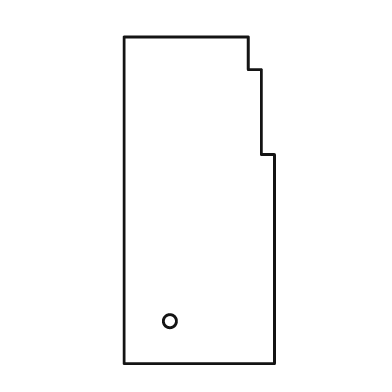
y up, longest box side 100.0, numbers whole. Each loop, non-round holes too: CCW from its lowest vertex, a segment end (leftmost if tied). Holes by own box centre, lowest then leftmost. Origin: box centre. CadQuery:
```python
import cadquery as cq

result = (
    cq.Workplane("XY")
    .moveTo(-23.0, -50.0)
    .lineTo(23.0, -50.0)
    .lineTo(23.0, 14.0)
    .lineTo(19.0, 14.0)
    .lineTo(19.0, 40.0)
    .lineTo(15.0, 40.0)
    .lineTo(15.0, 50.0)
    .lineTo(-23.0, 50.0)
    .close()
    .moveTo(-9.0, -37.0)
    .circle(2.0)
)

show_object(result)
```